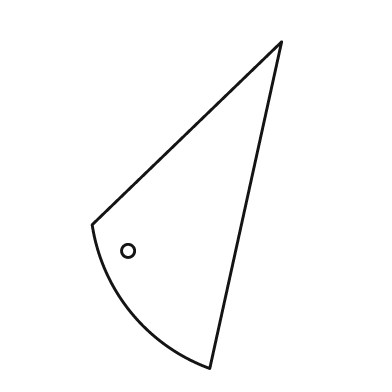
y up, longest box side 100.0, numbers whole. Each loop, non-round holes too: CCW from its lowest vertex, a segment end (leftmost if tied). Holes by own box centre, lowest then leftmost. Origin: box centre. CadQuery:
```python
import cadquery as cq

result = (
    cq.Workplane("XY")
    .moveTo(7.0, -50.0)
    .lineTo(29.0, 50.0)
    .lineTo(-29.0, -6.0)
    .threePointArc((-17.0, -33.0), (7.0, -50.0))
    .close()
    .moveTo(-18.0, -14.0)
    .circle(2.0)
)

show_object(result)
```